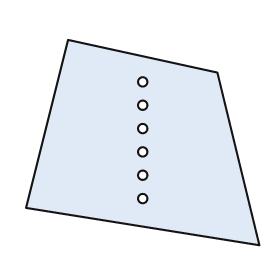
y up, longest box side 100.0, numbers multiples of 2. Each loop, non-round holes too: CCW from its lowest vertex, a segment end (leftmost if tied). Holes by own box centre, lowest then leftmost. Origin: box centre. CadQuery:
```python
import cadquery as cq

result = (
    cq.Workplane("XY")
    .moveTo(50.0, -44.0)
    .lineTo(32.0, 30.0)
    .lineTo(-32.0, 44.0)
    .lineTo(-50.0, -28.0)
    .close()
    .moveTo(0.0, -24.0)
    .circle(2.0)
    .moveTo(0.0, -14.0)
    .circle(2.0)
    .moveTo(0.0, -4.0)
    .circle(2.0)
    .moveTo(0.0, 6.0)
    .circle(2.0)
    .moveTo(0.0, 16.0)
    .circle(2.0)
    .moveTo(0.0, 26.0)
    .circle(2.0)
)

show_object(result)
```